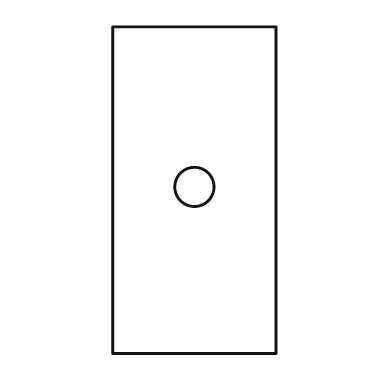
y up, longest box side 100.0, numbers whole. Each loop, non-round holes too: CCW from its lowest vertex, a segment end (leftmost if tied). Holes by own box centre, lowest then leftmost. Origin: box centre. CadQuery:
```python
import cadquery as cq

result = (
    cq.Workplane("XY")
    .moveTo(-25.0, -50.0)
    .lineTo(25.0, -50.0)
    .lineTo(25.0, 50.0)
    .lineTo(-25.0, 50.0)
    .close()
    .moveTo(0.0, 1.0)
    .circle(6.0)
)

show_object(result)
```